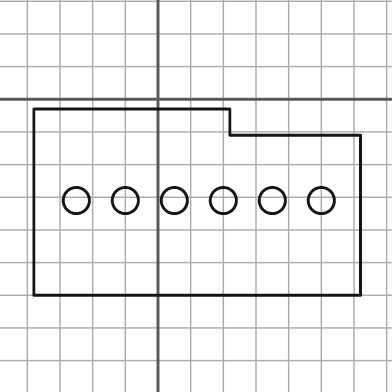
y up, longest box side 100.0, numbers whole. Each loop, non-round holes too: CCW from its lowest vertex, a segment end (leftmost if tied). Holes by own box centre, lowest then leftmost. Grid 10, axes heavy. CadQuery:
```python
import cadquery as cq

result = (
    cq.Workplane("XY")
    .moveTo(-38.0, -60.0)
    .lineTo(62.0, -60.0)
    .lineTo(62.0, -11.0)
    .lineTo(22.0, -11.0)
    .lineTo(22.0, -3.0)
    .lineTo(-38.0, -3.0)
    .close()
    .moveTo(-25.0, -31.0)
    .circle(4.0)
    .moveTo(-10.0, -31.0)
    .circle(4.0)
    .moveTo(5.0, -31.0)
    .circle(4.0)
    .moveTo(20.0, -31.0)
    .circle(4.0)
    .moveTo(35.0, -31.0)
    .circle(4.0)
    .moveTo(50.0, -31.0)
    .circle(4.0)
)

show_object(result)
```